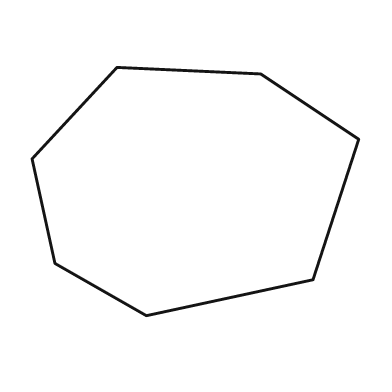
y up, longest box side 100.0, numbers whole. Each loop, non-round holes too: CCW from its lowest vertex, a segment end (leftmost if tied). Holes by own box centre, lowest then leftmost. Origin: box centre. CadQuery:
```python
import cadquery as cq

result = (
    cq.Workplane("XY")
    .moveTo(-15.0, -38.0)
    .lineTo(36.0, -27.0)
    .lineTo(50.0, 16.0)
    .lineTo(20.0, 36.0)
    .lineTo(-24.0, 38.0)
    .lineTo(-50.0, 10.0)
    .lineTo(-43.0, -22.0)
    .close()
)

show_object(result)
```